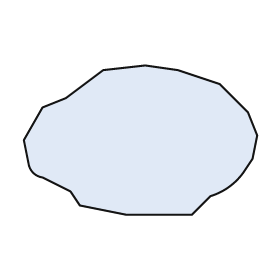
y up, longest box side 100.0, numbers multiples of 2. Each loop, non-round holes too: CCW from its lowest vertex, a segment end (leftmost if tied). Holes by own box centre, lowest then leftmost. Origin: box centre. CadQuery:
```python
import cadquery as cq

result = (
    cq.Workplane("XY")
    .moveTo(-6.0, -32.0)
    .lineTo(22.0, -32.0)
    .lineTo(30.0, -24.0)
    .threePointArc((38.0, -20.0), (44.0, -14.0))
    .lineTo(48.0, -8.0)
    .lineTo(50.0, 2.0)
    .lineTo(46.0, 12.0)
    .lineTo(34.0, 24.0)
    .lineTo(16.0, 30.0)
    .lineTo(2.0, 32.0)
    .lineTo(-16.0, 30.0)
    .lineTo(-32.0, 18.0)
    .lineTo(-42.0, 14.0)
    .lineTo(-50.0, 0.0)
    .lineTo(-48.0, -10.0)
    .threePointArc((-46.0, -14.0), (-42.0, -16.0))
    .lineTo(-30.0, -22.0)
    .lineTo(-26.0, -28.0)
    .close()
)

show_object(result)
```